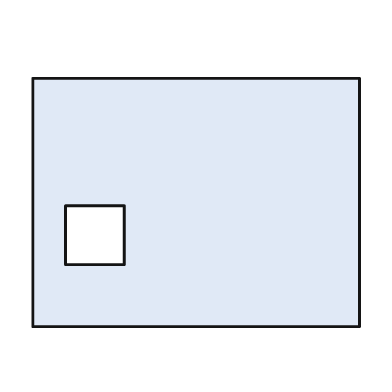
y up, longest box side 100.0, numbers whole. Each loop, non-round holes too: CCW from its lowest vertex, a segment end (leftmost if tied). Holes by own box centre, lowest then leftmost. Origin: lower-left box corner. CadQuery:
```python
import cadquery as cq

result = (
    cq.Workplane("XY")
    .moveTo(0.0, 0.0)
    .lineTo(100.0, 0.0)
    .lineTo(100.0, 76.0)
    .lineTo(0.0, 76.0)
    .close()
    .moveTo(10.0, 19.0)
    .lineTo(28.0, 19.0)
    .lineTo(28.0, 37.0)
    .lineTo(10.0, 37.0)
    .close()
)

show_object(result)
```